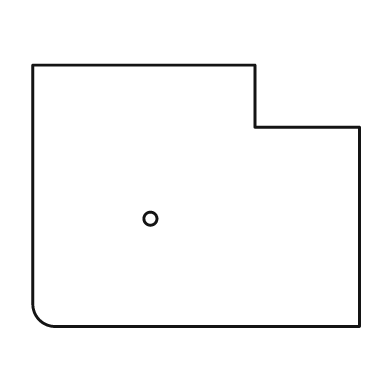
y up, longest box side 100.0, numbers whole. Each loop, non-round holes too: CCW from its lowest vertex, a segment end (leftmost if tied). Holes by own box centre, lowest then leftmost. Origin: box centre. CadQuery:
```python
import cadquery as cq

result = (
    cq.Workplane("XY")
    .moveTo(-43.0, -40.0)
    .lineTo(50.0, -40.0)
    .lineTo(50.0, 21.0)
    .lineTo(18.0, 21.0)
    .lineTo(18.0, 40.0)
    .lineTo(-50.0, 40.0)
    .lineTo(-50.0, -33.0)
    .threePointArc((-48.0, -38.0), (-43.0, -40.0))
    .close()
    .moveTo(-14.0, -7.0)
    .circle(2.0)
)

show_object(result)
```